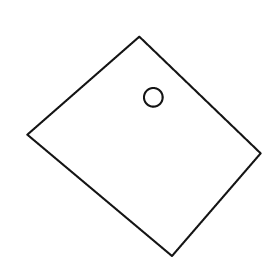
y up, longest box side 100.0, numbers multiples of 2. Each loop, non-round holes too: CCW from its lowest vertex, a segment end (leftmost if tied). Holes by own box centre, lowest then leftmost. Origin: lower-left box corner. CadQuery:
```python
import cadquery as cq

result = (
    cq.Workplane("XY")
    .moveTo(62.0, 0.0)
    .lineTo(100.0, 44.0)
    .lineTo(48.0, 94.0)
    .lineTo(0.0, 52.0)
    .close()
    .moveTo(54.0, 68.0)
    .circle(4.0)
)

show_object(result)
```